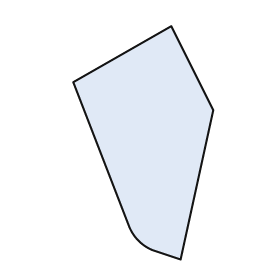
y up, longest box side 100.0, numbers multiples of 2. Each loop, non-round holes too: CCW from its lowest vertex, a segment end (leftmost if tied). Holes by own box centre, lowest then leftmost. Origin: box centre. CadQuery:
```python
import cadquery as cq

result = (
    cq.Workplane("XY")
    .moveTo(16.0, -50.0)
    .lineTo(30.0, 14.0)
    .lineTo(12.0, 50.0)
    .lineTo(-30.0, 26.0)
    .lineTo(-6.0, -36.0)
    .threePointArc((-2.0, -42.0), (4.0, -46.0))
    .close()
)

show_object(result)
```